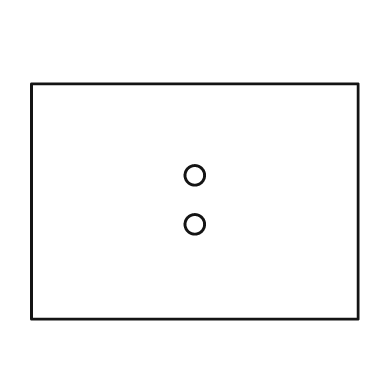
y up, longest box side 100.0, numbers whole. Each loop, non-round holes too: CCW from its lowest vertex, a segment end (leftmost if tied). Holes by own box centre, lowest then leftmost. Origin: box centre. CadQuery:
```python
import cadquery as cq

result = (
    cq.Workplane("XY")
    .moveTo(-50.0, -36.0)
    .lineTo(50.0, -36.0)
    .lineTo(50.0, 36.0)
    .lineTo(-50.0, 36.0)
    .close()
    .moveTo(0.0, -7.0)
    .circle(3.0)
    .moveTo(0.0, 8.0)
    .circle(3.0)
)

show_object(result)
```